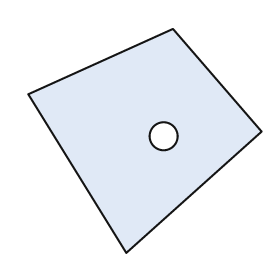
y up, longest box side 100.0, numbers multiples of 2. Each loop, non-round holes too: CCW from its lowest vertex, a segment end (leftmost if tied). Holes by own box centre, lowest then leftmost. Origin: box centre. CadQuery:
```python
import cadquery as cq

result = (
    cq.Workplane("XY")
    .moveTo(-8.0, -48.0)
    .lineTo(50.0, 4.0)
    .lineTo(12.0, 48.0)
    .lineTo(-50.0, 20.0)
    .close()
    .moveTo(8.0, 2.0)
    .circle(6.0)
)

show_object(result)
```